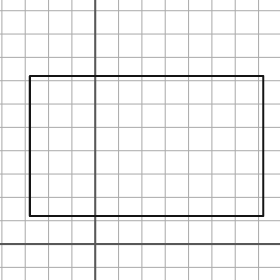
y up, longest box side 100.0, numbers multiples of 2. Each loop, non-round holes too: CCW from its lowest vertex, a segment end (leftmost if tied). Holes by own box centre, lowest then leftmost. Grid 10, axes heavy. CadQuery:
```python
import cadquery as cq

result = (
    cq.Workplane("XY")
    .moveTo(-28.0, 12.0)
    .lineTo(72.0, 12.0)
    .lineTo(72.0, 72.0)
    .lineTo(-28.0, 72.0)
    .close()
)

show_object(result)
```